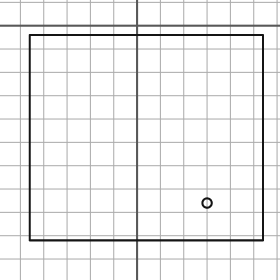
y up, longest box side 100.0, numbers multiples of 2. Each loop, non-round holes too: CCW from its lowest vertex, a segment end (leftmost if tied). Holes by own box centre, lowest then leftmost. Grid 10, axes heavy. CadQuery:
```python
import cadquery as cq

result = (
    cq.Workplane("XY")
    .moveTo(-46.0, -92.0)
    .lineTo(54.0, -92.0)
    .lineTo(54.0, -4.0)
    .lineTo(-46.0, -4.0)
    .close()
    .moveTo(30.0, -76.0)
    .circle(2.0)
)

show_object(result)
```